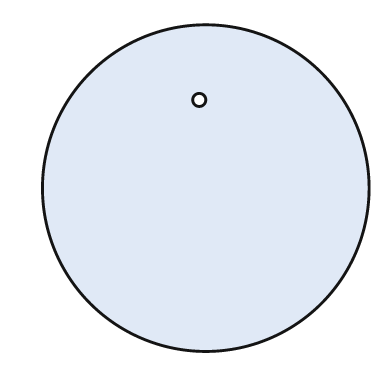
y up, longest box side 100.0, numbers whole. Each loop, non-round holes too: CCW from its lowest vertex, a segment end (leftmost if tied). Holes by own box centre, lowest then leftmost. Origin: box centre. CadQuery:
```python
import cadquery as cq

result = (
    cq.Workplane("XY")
    .moveTo(0.0, 0.0)
    .circle(50.0)
    .moveTo(-2.0, 27.0)
    .circle(2.0)
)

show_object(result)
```